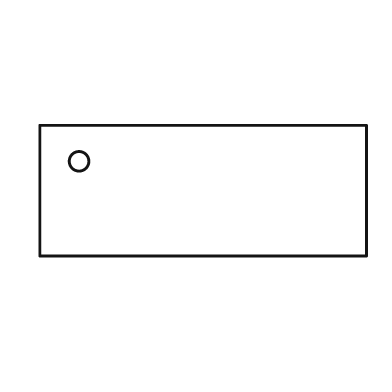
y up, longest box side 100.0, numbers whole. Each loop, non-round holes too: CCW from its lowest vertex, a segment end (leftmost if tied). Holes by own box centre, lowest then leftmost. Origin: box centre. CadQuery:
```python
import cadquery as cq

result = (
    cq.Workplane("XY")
    .moveTo(-50.0, -20.0)
    .lineTo(50.0, -20.0)
    .lineTo(50.0, 20.0)
    .lineTo(-50.0, 20.0)
    .close()
    .moveTo(-38.0, 9.0)
    .circle(3.0)
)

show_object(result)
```